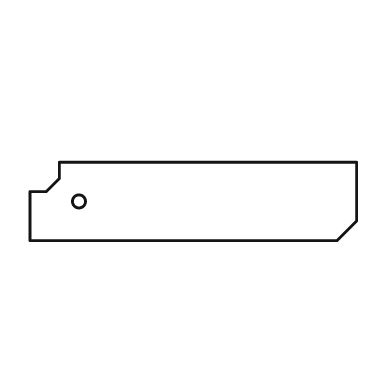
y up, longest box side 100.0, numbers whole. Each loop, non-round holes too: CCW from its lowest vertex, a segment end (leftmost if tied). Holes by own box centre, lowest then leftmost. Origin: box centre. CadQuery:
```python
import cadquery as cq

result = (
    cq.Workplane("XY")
    .moveTo(-50.0, -12.0)
    .lineTo(44.0, -12.0)
    .lineTo(50.0, -6.0)
    .lineTo(50.0, 12.0)
    .lineTo(-41.0, 12.0)
    .lineTo(-41.0, 7.0)
    .lineTo(-45.0, 3.0)
    .lineTo(-50.0, 3.0)
    .close()
    .moveTo(-35.0, 0.0)
    .circle(2.0)
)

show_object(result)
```